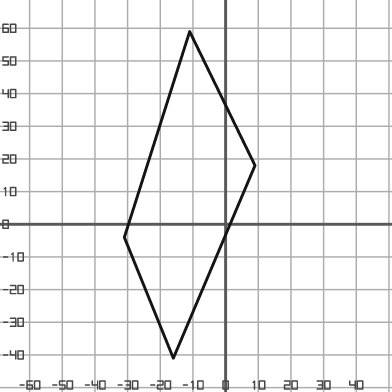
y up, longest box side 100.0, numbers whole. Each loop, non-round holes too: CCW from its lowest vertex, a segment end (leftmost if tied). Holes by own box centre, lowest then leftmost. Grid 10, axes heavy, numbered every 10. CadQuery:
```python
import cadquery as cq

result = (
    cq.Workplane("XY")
    .moveTo(-16.0, -41.0)
    .lineTo(9.0, 18.0)
    .lineTo(-11.0, 59.0)
    .lineTo(-31.0, -4.0)
    .close()
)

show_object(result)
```